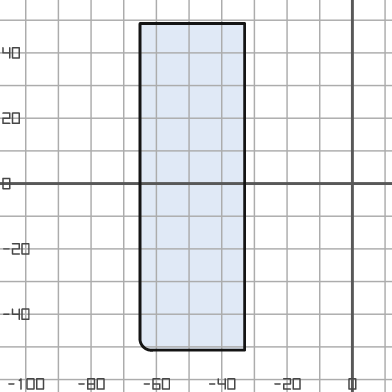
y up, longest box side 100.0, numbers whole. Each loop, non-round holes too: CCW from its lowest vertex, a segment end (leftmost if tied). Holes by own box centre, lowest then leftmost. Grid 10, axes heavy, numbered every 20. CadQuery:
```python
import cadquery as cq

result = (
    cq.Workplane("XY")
    .moveTo(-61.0, -51.0)
    .lineTo(-33.0, -51.0)
    .lineTo(-33.0, 49.0)
    .lineTo(-65.0, 49.0)
    .lineTo(-65.0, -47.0)
    .threePointArc((-64.0, -50.0), (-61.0, -51.0))
    .close()
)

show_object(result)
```